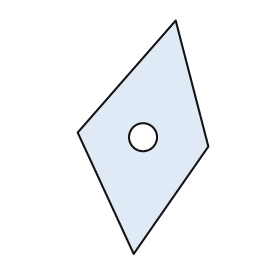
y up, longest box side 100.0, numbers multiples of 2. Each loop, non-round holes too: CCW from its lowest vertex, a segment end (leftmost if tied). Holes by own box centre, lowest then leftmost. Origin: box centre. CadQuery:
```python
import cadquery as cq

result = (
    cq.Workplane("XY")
    .moveTo(-4.0, -50.0)
    .lineTo(28.0, -4.0)
    .lineTo(14.0, 50.0)
    .lineTo(-28.0, 2.0)
    .close()
    .moveTo(0.0, 0.0)
    .circle(6.0)
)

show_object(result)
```